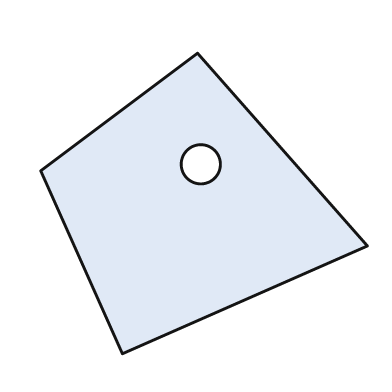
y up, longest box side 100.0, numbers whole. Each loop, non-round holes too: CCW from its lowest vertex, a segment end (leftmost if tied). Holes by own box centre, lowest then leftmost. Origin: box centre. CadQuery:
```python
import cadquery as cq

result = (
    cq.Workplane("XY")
    .moveTo(-25.0, -46.0)
    .lineTo(50.0, -13.0)
    .lineTo(-2.0, 46.0)
    .lineTo(-50.0, 10.0)
    .close()
    .moveTo(-1.0, 12.0)
    .circle(6.0)
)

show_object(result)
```